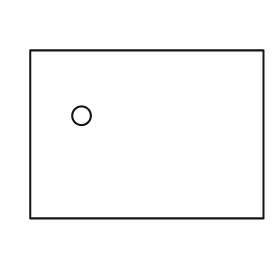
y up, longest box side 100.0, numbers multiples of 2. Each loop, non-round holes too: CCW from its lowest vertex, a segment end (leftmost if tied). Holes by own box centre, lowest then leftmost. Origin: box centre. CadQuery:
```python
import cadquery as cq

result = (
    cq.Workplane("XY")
    .moveTo(-50.0, -36.0)
    .lineTo(50.0, -36.0)
    .lineTo(50.0, 36.0)
    .lineTo(-50.0, 36.0)
    .close()
    .moveTo(-28.0, 8.0)
    .circle(4.0)
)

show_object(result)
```